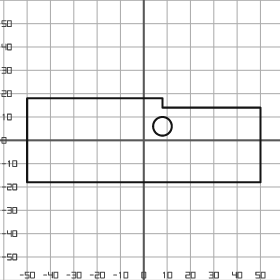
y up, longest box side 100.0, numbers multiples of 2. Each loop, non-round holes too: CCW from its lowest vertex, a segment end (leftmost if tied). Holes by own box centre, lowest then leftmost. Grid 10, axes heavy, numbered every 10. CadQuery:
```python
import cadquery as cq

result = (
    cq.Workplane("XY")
    .moveTo(-50.0, -18.0)
    .lineTo(50.0, -18.0)
    .lineTo(50.0, 14.0)
    .lineTo(8.0, 14.0)
    .lineTo(8.0, 18.0)
    .lineTo(-50.0, 18.0)
    .close()
    .moveTo(8.0, 6.0)
    .circle(4.0)
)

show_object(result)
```